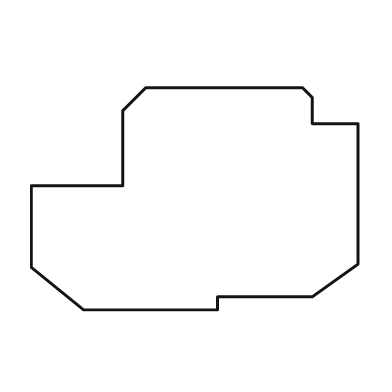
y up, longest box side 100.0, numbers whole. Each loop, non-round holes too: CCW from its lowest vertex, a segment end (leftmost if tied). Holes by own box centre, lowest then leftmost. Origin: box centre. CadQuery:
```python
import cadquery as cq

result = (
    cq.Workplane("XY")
    .moveTo(-34.0, -34.0)
    .lineTo(7.0, -34.0)
    .lineTo(7.0, -30.0)
    .lineTo(36.0, -30.0)
    .lineTo(50.0, -20.0)
    .lineTo(50.0, 23.0)
    .lineTo(36.0, 23.0)
    .lineTo(36.0, 31.0)
    .lineTo(33.0, 34.0)
    .lineTo(-15.0, 34.0)
    .lineTo(-22.0, 27.0)
    .lineTo(-22.0, 4.0)
    .lineTo(-50.0, 4.0)
    .lineTo(-50.0, -21.0)
    .close()
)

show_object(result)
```